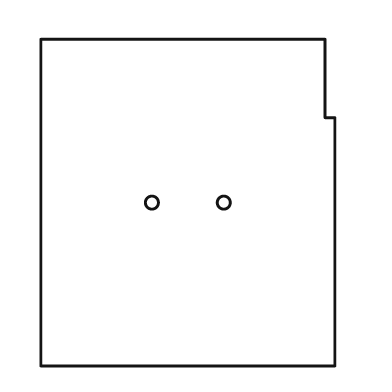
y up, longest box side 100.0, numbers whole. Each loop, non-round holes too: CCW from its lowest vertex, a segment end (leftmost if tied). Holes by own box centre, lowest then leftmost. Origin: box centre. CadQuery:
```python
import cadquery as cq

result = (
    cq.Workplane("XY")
    .moveTo(-45.0, -50.0)
    .lineTo(45.0, -50.0)
    .lineTo(45.0, 26.0)
    .lineTo(42.0, 26.0)
    .lineTo(42.0, 50.0)
    .lineTo(-45.0, 50.0)
    .close()
    .moveTo(-11.0, 0.0)
    .circle(2.0)
    .moveTo(11.0, 0.0)
    .circle(2.0)
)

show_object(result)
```